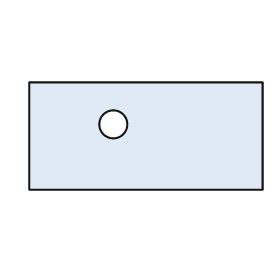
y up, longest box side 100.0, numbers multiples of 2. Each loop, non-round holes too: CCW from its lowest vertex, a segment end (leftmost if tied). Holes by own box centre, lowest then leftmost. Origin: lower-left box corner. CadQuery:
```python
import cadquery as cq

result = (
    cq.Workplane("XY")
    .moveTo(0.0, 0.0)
    .lineTo(100.0, 0.0)
    .lineTo(100.0, 46.0)
    .lineTo(0.0, 46.0)
    .close()
    .moveTo(36.0, 28.0)
    .circle(6.0)
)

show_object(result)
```